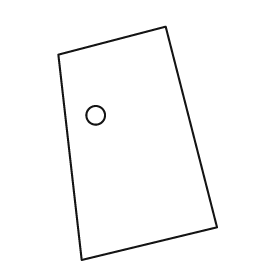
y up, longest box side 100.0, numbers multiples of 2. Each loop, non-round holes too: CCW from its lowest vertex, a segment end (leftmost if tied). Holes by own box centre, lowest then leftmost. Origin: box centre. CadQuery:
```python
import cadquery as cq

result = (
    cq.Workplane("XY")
    .moveTo(-24.0, -50.0)
    .lineTo(34.0, -36.0)
    .lineTo(12.0, 50.0)
    .lineTo(-34.0, 38.0)
    .close()
    .moveTo(-18.0, 12.0)
    .circle(4.0)
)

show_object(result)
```